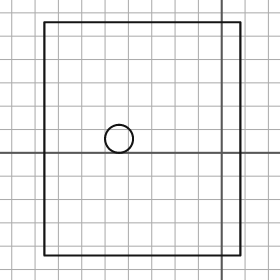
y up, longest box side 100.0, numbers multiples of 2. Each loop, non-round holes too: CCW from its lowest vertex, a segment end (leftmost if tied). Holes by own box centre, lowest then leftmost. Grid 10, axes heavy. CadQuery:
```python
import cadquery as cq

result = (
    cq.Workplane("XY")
    .moveTo(-76.0, -44.0)
    .lineTo(8.0, -44.0)
    .lineTo(8.0, 56.0)
    .lineTo(-76.0, 56.0)
    .close()
    .moveTo(-44.0, 6.0)
    .circle(6.0)
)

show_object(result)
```